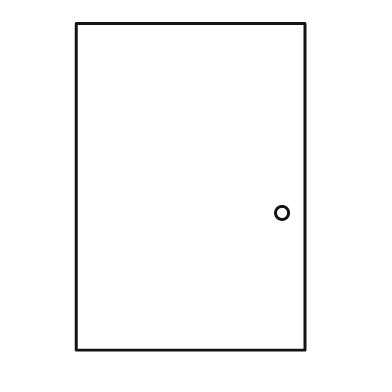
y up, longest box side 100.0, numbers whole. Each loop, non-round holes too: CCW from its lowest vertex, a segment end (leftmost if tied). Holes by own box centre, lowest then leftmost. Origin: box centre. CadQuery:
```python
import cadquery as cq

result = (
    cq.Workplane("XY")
    .moveTo(-35.0, -50.0)
    .lineTo(35.0, -50.0)
    .lineTo(35.0, 50.0)
    .lineTo(-35.0, 50.0)
    .close()
    .moveTo(28.0, -8.0)
    .circle(2.0)
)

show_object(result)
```